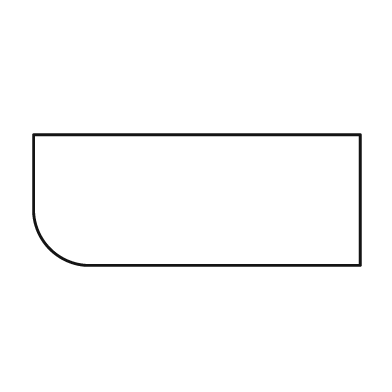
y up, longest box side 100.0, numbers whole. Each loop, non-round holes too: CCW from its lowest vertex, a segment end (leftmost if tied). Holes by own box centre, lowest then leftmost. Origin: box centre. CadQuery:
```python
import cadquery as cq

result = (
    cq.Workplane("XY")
    .moveTo(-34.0, -20.0)
    .lineTo(50.0, -20.0)
    .lineTo(50.0, 20.0)
    .lineTo(-50.0, 20.0)
    .lineTo(-50.0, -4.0)
    .threePointArc((-45.0, -15.0), (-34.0, -20.0))
    .close()
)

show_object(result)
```